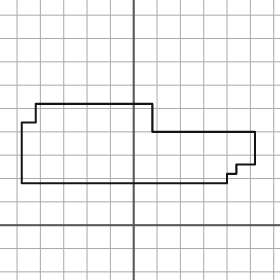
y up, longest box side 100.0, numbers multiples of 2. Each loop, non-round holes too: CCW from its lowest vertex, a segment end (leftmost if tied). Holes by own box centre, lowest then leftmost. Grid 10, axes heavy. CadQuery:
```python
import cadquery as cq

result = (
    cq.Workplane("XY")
    .moveTo(-48.0, 18.0)
    .lineTo(40.0, 18.0)
    .lineTo(40.0, 22.0)
    .lineTo(44.0, 22.0)
    .lineTo(44.0, 26.0)
    .lineTo(52.0, 26.0)
    .lineTo(52.0, 40.0)
    .lineTo(8.0, 40.0)
    .lineTo(8.0, 52.0)
    .lineTo(-42.0, 52.0)
    .lineTo(-42.0, 44.0)
    .lineTo(-48.0, 44.0)
    .close()
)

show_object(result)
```